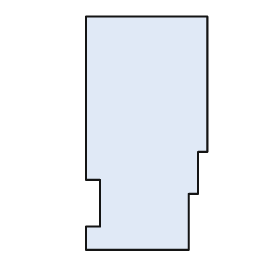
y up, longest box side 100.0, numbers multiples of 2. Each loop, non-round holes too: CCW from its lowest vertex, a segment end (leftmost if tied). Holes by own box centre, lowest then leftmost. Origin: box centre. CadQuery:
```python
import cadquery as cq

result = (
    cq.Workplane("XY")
    .moveTo(-26.0, -50.0)
    .lineTo(18.0, -50.0)
    .lineTo(18.0, -26.0)
    .lineTo(22.0, -26.0)
    .lineTo(22.0, -8.0)
    .lineTo(26.0, -8.0)
    .lineTo(26.0, 50.0)
    .lineTo(-26.0, 50.0)
    .lineTo(-26.0, -20.0)
    .lineTo(-20.0, -20.0)
    .lineTo(-20.0, -40.0)
    .lineTo(-26.0, -40.0)
    .close()
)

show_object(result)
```